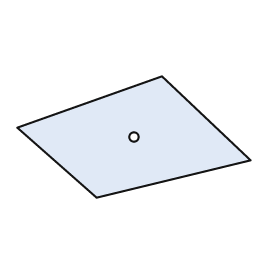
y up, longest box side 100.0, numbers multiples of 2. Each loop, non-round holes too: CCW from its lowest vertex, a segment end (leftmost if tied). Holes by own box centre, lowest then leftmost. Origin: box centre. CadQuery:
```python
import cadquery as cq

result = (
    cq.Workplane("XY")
    .moveTo(-16.0, -26.0)
    .lineTo(50.0, -10.0)
    .lineTo(12.0, 26.0)
    .lineTo(-50.0, 4.0)
    .close()
    .moveTo(0.0, 0.0)
    .circle(2.0)
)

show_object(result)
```